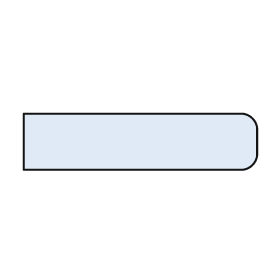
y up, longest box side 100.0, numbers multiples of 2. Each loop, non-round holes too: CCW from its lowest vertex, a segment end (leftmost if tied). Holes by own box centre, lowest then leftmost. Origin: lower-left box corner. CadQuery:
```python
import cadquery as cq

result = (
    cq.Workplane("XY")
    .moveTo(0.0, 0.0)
    .lineTo(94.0, 0.0)
    .threePointArc((98.0, 2.0), (100.0, 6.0))
    .lineTo(100.0, 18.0)
    .threePointArc((98.0, 22.0), (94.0, 24.0))
    .lineTo(0.0, 24.0)
    .close()
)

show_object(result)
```